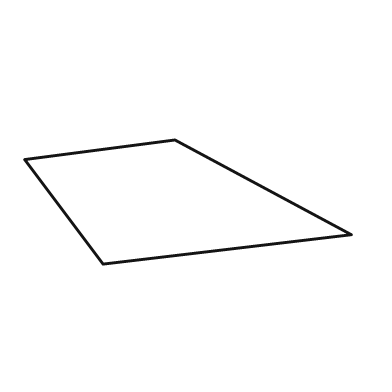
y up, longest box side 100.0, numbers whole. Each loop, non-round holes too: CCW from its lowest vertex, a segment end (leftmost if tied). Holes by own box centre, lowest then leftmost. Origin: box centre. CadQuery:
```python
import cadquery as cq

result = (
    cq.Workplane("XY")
    .moveTo(-26.0, -19.0)
    .lineTo(50.0, -10.0)
    .lineTo(-4.0, 19.0)
    .lineTo(-50.0, 13.0)
    .close()
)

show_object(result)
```